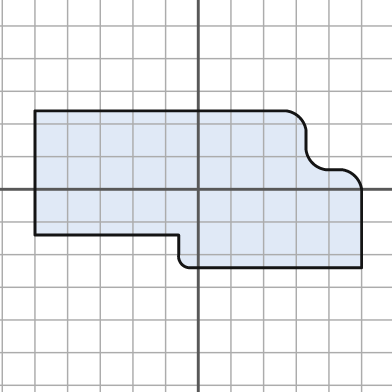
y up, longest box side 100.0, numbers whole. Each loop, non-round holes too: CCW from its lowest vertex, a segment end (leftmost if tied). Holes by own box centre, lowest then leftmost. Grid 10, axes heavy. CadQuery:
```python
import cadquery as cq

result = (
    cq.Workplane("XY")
    .moveTo(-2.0, -24.0)
    .lineTo(50.0, -24.0)
    .lineTo(50.0, 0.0)
    .threePointArc((48.0, 4.0), (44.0, 6.0))
    .lineTo(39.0, 6.0)
    .threePointArc((35.0, 8.0), (33.0, 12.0))
    .lineTo(33.0, 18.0)
    .threePointArc((31.0, 22.0), (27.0, 24.0))
    .lineTo(-50.0, 24.0)
    .lineTo(-50.0, -14.0)
    .lineTo(-6.0, -14.0)
    .lineTo(-6.0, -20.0)
    .threePointArc((-5.0, -23.0), (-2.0, -24.0))
    .close()
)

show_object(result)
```